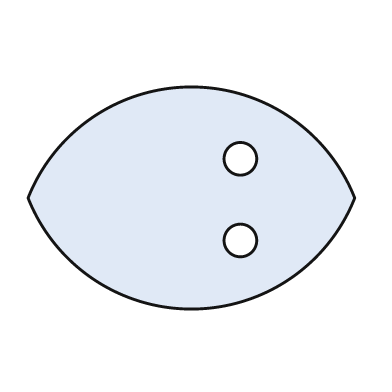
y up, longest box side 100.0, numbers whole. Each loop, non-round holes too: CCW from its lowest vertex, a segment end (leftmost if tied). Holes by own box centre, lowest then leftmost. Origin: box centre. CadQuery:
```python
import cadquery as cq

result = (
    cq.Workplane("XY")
    .moveTo(-50.0, 0.0)
    .threePointArc((0.0, -34.0), (50.0, 0.0))
    .threePointArc((0.0, 34.0), (-50.0, 0.0))
    .close()
    .moveTo(15.0, -13.0)
    .circle(5.0)
    .moveTo(15.0, 12.0)
    .circle(5.0)
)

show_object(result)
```